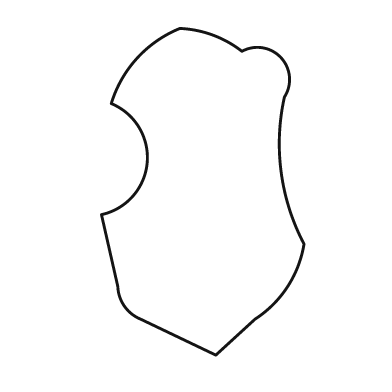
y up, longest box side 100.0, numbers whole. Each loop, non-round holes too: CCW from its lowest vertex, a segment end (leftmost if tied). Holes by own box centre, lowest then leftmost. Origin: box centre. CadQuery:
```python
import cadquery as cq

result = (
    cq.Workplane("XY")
    .moveTo(4.0, -50.0)
    .lineTo(16.0, -39.0)
    .threePointArc((26.0, -29.0), (31.0, -16.0))
    .threePointArc((24.0, 6.0), (25.0, 29.0))
    .threePointArc((24.0, 41.0), (12.0, 43.0))
    .threePointArc((3.0, 48.0), (-7.0, 50.0))
    .threePointArc((-20.0, 41.0), (-28.0, 27.0))
    .threePointArc((-17.0, 9.0), (-31.0, -7.0))
    .lineTo(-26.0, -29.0)
    .threePointArc((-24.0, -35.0), (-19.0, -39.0))
    .close()
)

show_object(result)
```